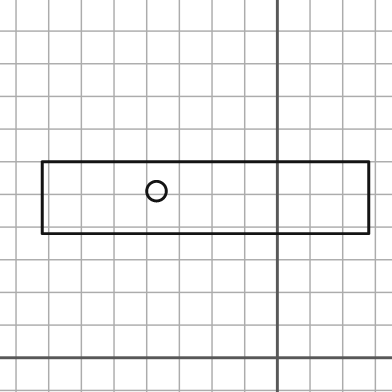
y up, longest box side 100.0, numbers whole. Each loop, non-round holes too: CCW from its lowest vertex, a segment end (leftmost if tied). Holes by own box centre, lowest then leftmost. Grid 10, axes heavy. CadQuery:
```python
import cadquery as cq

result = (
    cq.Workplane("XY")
    .moveTo(-72.0, 38.0)
    .lineTo(28.0, 38.0)
    .lineTo(28.0, 60.0)
    .lineTo(-72.0, 60.0)
    .close()
    .moveTo(-37.0, 51.0)
    .circle(3.0)
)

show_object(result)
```